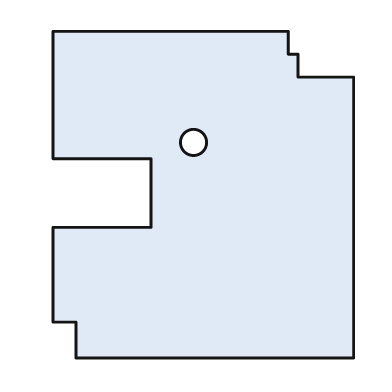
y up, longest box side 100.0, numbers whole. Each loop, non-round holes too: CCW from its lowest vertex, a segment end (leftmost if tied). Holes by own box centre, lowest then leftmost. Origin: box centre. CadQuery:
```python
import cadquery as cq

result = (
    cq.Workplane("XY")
    .moveTo(-39.0, -50.0)
    .lineTo(46.0, -50.0)
    .lineTo(46.0, 36.0)
    .lineTo(29.0, 36.0)
    .lineTo(29.0, 43.0)
    .lineTo(26.0, 43.0)
    .lineTo(26.0, 50.0)
    .lineTo(-46.0, 50.0)
    .lineTo(-46.0, 11.0)
    .lineTo(-16.0, 11.0)
    .lineTo(-16.0, -10.0)
    .lineTo(-46.0, -10.0)
    .lineTo(-46.0, -39.0)
    .lineTo(-39.0, -39.0)
    .close()
    .moveTo(-3.0, 16.0)
    .circle(4.0)
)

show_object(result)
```